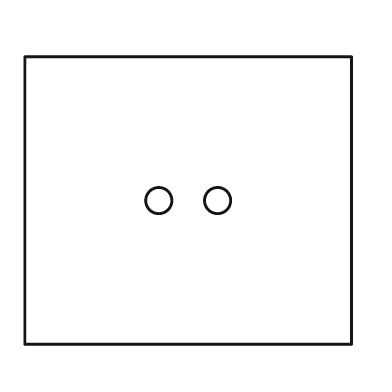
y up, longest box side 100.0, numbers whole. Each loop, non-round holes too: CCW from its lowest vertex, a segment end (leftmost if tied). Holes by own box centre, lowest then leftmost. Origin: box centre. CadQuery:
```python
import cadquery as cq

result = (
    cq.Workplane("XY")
    .moveTo(-50.0, -44.0)
    .lineTo(50.0, -44.0)
    .lineTo(50.0, 44.0)
    .lineTo(-50.0, 44.0)
    .close()
    .moveTo(-9.0, 0.0)
    .circle(4.0)
    .moveTo(9.0, 0.0)
    .circle(4.0)
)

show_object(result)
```